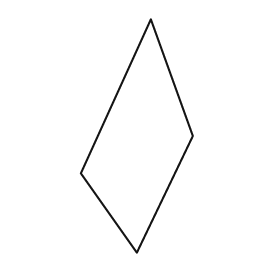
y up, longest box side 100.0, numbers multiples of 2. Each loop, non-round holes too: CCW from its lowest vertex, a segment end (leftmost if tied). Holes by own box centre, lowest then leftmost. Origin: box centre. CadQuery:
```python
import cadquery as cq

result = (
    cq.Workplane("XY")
    .moveTo(0.0, -50.0)
    .lineTo(24.0, 0.0)
    .lineTo(6.0, 50.0)
    .lineTo(-24.0, -16.0)
    .close()
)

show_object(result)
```